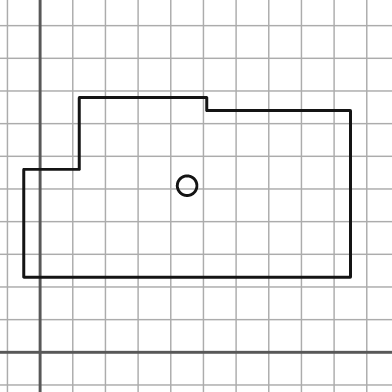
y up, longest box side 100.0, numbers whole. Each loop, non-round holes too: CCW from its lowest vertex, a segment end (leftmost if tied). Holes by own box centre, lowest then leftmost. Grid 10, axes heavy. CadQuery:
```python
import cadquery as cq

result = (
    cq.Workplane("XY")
    .moveTo(-5.0, 23.0)
    .lineTo(95.0, 23.0)
    .lineTo(95.0, 74.0)
    .lineTo(51.0, 74.0)
    .lineTo(51.0, 78.0)
    .lineTo(12.0, 78.0)
    .lineTo(12.0, 56.0)
    .lineTo(-5.0, 56.0)
    .close()
    .moveTo(45.0, 51.0)
    .circle(3.0)
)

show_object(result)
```